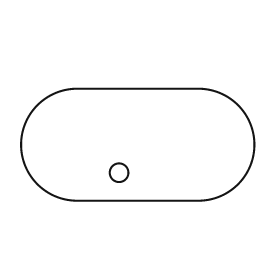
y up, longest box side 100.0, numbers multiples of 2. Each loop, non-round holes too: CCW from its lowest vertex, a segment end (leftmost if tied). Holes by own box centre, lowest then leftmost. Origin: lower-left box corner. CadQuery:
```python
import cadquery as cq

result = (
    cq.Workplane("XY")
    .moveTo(24.0, 0.0)
    .lineTo(76.0, 0.0)
    .threePointArc((100.0, 24.0), (76.0, 48.0))
    .lineTo(24.0, 48.0)
    .threePointArc((0.0, 24.0), (24.0, 0.0))
    .close()
    .moveTo(42.0, 12.0)
    .circle(4.0)
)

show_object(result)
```